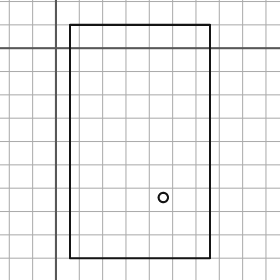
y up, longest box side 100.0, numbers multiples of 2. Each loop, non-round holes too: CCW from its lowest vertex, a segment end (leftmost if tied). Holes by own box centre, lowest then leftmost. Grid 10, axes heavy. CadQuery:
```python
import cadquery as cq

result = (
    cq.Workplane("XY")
    .moveTo(6.0, -90.0)
    .lineTo(66.0, -90.0)
    .lineTo(66.0, 10.0)
    .lineTo(6.0, 10.0)
    .close()
    .moveTo(46.0, -64.0)
    .circle(2.0)
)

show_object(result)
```